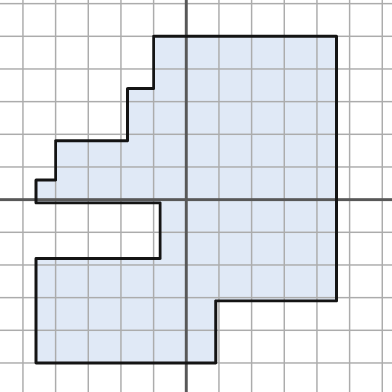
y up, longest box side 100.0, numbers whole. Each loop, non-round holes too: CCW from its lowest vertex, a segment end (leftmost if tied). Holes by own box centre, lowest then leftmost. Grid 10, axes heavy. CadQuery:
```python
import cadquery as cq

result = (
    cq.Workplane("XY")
    .moveTo(-46.0, -50.0)
    .lineTo(9.0, -50.0)
    .lineTo(9.0, -31.0)
    .lineTo(46.0, -31.0)
    .lineTo(46.0, 50.0)
    .lineTo(-10.0, 50.0)
    .lineTo(-10.0, 34.0)
    .lineTo(-18.0, 34.0)
    .lineTo(-18.0, 18.0)
    .lineTo(-40.0, 18.0)
    .lineTo(-40.0, 6.0)
    .lineTo(-46.0, 6.0)
    .lineTo(-46.0, -1.0)
    .lineTo(-8.0, -1.0)
    .lineTo(-8.0, -18.0)
    .lineTo(-46.0, -18.0)
    .close()
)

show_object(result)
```